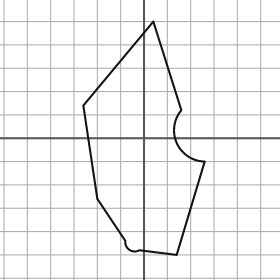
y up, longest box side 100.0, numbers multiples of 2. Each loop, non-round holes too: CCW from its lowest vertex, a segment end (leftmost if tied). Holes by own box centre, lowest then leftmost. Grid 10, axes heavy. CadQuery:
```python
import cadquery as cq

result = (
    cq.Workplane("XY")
    .moveTo(14.0, -50.0)
    .lineTo(26.0, -10.0)
    .threePointArc((14.0, -2.0), (16.0, 12.0))
    .lineTo(4.0, 50.0)
    .lineTo(-26.0, 14.0)
    .lineTo(-20.0, -26.0)
    .lineTo(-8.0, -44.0)
    .threePointArc((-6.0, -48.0), (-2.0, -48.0))
    .close()
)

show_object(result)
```